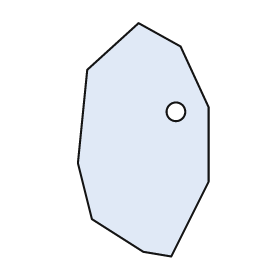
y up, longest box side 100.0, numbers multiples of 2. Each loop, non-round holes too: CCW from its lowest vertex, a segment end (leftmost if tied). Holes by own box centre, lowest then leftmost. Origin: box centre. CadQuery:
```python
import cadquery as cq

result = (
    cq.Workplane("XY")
    .moveTo(12.0, -50.0)
    .lineTo(28.0, -18.0)
    .lineTo(28.0, 14.0)
    .lineTo(16.0, 40.0)
    .lineTo(-2.0, 50.0)
    .lineTo(-24.0, 30.0)
    .lineTo(-28.0, -10.0)
    .lineTo(-22.0, -34.0)
    .lineTo(0.0, -48.0)
    .close()
    .moveTo(14.0, 12.0)
    .circle(4.0)
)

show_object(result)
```